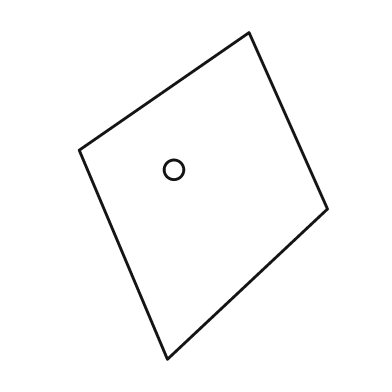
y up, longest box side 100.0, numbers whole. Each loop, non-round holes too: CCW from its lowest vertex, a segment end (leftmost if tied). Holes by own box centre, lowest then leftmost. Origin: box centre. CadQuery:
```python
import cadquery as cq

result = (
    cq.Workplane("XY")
    .moveTo(-11.0, -50.0)
    .lineTo(38.0, -4.0)
    .lineTo(14.0, 50.0)
    .lineTo(-38.0, 14.0)
    .close()
    .moveTo(-9.0, 8.0)
    .circle(3.0)
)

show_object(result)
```